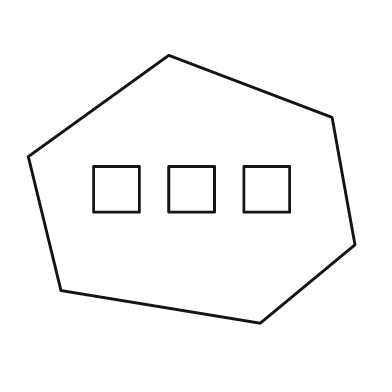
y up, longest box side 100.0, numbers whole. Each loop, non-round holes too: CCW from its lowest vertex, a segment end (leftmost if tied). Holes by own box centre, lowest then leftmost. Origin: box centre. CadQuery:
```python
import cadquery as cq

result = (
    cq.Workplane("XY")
    .moveTo(21.0, -41.0)
    .lineTo(50.0, -17.0)
    .lineTo(43.0, 22.0)
    .lineTo(-7.0, 41.0)
    .lineTo(-50.0, 10.0)
    .lineTo(-40.0, -31.0)
    .close()
    .moveTo(-30.0, -7.0)
    .lineTo(-16.0, -7.0)
    .lineTo(-16.0, 7.0)
    .lineTo(-30.0, 7.0)
    .close()
    .moveTo(-7.0, -7.0)
    .lineTo(7.0, -7.0)
    .lineTo(7.0, 7.0)
    .lineTo(-7.0, 7.0)
    .close()
    .moveTo(16.0, -7.0)
    .lineTo(30.0, -7.0)
    .lineTo(30.0, 7.0)
    .lineTo(16.0, 7.0)
    .close()
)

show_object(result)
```